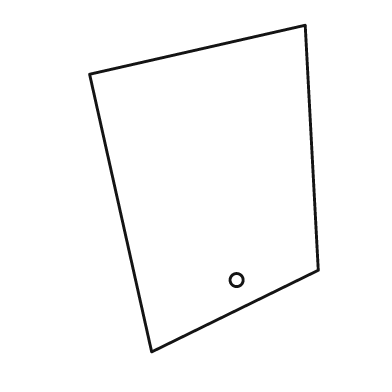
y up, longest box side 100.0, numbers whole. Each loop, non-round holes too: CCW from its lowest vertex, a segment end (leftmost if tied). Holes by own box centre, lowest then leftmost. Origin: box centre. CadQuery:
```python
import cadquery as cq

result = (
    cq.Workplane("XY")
    .moveTo(-16.0, -50.0)
    .lineTo(35.0, -25.0)
    .lineTo(31.0, 50.0)
    .lineTo(-35.0, 35.0)
    .close()
    .moveTo(10.0, -28.0)
    .circle(2.0)
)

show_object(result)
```